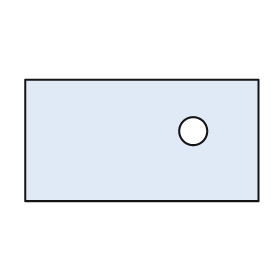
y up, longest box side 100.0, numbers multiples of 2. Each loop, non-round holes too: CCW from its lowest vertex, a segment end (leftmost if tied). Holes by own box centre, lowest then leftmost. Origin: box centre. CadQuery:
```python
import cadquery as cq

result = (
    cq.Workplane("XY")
    .moveTo(-50.0, -26.0)
    .lineTo(50.0, -26.0)
    .lineTo(50.0, 26.0)
    .lineTo(-50.0, 26.0)
    .close()
    .moveTo(22.0, 4.0)
    .circle(6.0)
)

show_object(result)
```